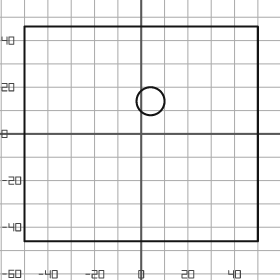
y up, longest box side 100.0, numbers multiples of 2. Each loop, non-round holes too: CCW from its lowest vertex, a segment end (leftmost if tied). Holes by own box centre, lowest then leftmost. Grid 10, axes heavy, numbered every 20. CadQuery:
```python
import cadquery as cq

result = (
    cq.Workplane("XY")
    .moveTo(-50.0, -46.0)
    .lineTo(50.0, -46.0)
    .lineTo(50.0, 46.0)
    .lineTo(-50.0, 46.0)
    .close()
    .moveTo(4.0, 14.0)
    .circle(6.0)
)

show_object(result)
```